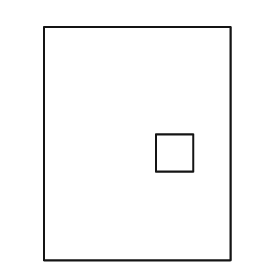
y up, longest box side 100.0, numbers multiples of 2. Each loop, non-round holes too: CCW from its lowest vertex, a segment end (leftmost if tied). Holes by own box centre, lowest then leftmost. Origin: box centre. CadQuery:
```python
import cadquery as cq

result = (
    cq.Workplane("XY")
    .moveTo(-40.0, -50.0)
    .lineTo(40.0, -50.0)
    .lineTo(40.0, 50.0)
    .lineTo(-40.0, 50.0)
    .close()
    .moveTo(8.0, -12.0)
    .lineTo(24.0, -12.0)
    .lineTo(24.0, 4.0)
    .lineTo(8.0, 4.0)
    .close()
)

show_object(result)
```